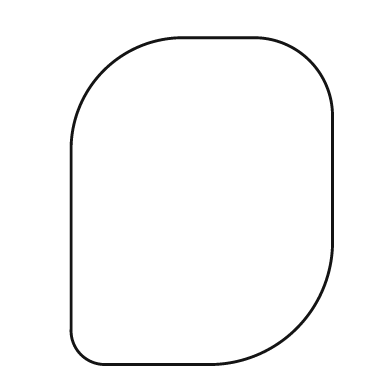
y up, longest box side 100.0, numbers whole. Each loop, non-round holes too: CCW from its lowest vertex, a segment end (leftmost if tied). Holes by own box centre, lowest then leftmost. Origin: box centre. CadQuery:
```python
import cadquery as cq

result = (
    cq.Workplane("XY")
    .moveTo(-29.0, -50.0)
    .lineTo(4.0, -50.0)
    .threePointArc((29.0, -39.0), (40.0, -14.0))
    .lineTo(40.0, 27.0)
    .threePointArc((33.0, 43.0), (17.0, 50.0))
    .lineTo(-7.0, 50.0)
    .threePointArc((-30.0, 40.0), (-40.0, 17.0))
    .lineTo(-40.0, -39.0)
    .threePointArc((-37.0, -47.0), (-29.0, -50.0))
    .close()
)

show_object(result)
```